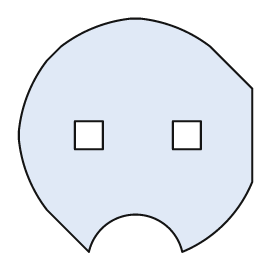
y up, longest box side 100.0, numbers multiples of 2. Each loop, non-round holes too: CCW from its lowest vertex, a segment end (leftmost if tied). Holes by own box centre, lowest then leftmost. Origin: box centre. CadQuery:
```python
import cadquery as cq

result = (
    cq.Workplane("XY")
    .moveTo(-20.0, -50.0)
    .threePointArc((0.0, -34.0), (20.0, -50.0))
    .threePointArc((38.0, -38.0), (50.0, -20.0))
    .lineTo(50.0, 20.0)
    .lineTo(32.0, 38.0)
    .threePointArc((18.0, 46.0), (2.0, 50.0))
    .lineTo(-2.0, 50.0)
    .threePointArc((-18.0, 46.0), (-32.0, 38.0))
    .lineTo(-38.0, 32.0)
    .threePointArc((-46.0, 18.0), (-50.0, 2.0))
    .lineTo(-50.0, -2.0)
    .threePointArc((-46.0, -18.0), (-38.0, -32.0))
    .close()
    .moveTo(-26.0, -6.0)
    .lineTo(-14.0, -6.0)
    .lineTo(-14.0, 6.0)
    .lineTo(-26.0, 6.0)
    .close()
    .moveTo(16.0, -6.0)
    .lineTo(28.0, -6.0)
    .lineTo(28.0, 6.0)
    .lineTo(16.0, 6.0)
    .close()
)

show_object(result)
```